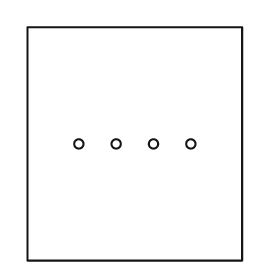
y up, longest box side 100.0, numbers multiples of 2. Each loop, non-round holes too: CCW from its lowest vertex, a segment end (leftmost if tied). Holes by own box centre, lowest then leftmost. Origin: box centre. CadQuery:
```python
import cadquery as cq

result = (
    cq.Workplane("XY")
    .moveTo(-46.0, -50.0)
    .lineTo(46.0, -50.0)
    .lineTo(46.0, 50.0)
    .lineTo(-46.0, 50.0)
    .close()
    .moveTo(-24.0, 0.0)
    .circle(2.0)
    .moveTo(-8.0, 0.0)
    .circle(2.0)
    .moveTo(8.0, 0.0)
    .circle(2.0)
    .moveTo(24.0, 0.0)
    .circle(2.0)
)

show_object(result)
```